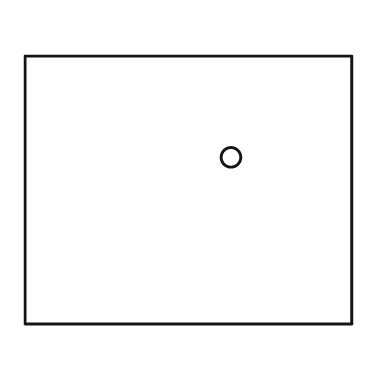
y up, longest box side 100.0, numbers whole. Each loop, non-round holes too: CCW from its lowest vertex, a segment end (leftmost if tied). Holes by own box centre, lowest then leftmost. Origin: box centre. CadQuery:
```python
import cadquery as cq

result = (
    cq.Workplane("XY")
    .moveTo(-50.0, -41.0)
    .lineTo(50.0, -41.0)
    .lineTo(50.0, 41.0)
    .lineTo(-50.0, 41.0)
    .close()
    .moveTo(13.0, 10.0)
    .circle(3.0)
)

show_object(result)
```